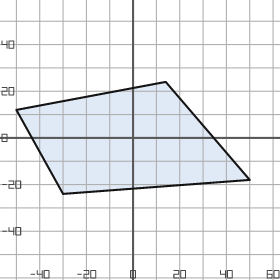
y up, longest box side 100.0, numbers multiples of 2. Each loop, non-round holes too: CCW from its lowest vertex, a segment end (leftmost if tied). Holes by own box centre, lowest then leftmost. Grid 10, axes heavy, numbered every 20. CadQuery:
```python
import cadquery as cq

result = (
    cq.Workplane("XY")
    .moveTo(-30.0, -24.0)
    .lineTo(50.0, -18.0)
    .lineTo(14.0, 24.0)
    .lineTo(-50.0, 12.0)
    .close()
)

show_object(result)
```